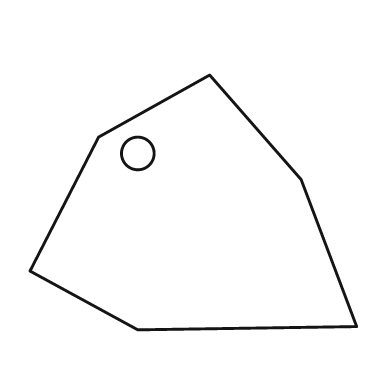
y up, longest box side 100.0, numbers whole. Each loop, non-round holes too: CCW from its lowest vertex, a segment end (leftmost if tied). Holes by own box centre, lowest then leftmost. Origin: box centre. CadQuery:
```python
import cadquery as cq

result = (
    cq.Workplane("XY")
    .moveTo(-17.0, -39.0)
    .lineTo(50.0, -38.0)
    .lineTo(33.0, 7.0)
    .lineTo(5.0, 39.0)
    .lineTo(-29.0, 20.0)
    .lineTo(-50.0, -21.0)
    .close()
    .moveTo(-17.0, 15.0)
    .circle(5.0)
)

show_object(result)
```